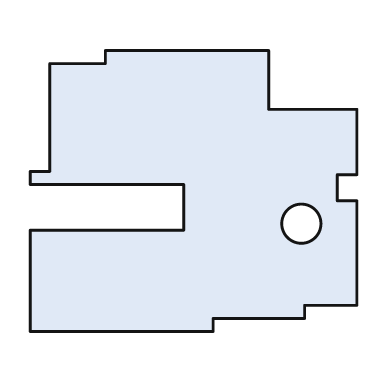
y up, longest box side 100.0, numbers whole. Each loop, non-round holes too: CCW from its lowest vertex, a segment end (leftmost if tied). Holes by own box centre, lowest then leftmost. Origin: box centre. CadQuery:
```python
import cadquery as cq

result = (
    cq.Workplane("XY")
    .moveTo(-50.0, -43.0)
    .lineTo(6.0, -43.0)
    .lineTo(6.0, -39.0)
    .lineTo(34.0, -39.0)
    .lineTo(34.0, -35.0)
    .lineTo(50.0, -35.0)
    .lineTo(50.0, -3.0)
    .lineTo(44.0, -3.0)
    .lineTo(44.0, 5.0)
    .lineTo(50.0, 5.0)
    .lineTo(50.0, 25.0)
    .lineTo(23.0, 25.0)
    .lineTo(23.0, 43.0)
    .lineTo(-27.0, 43.0)
    .lineTo(-27.0, 39.0)
    .lineTo(-44.0, 39.0)
    .lineTo(-44.0, 6.0)
    .lineTo(-50.0, 6.0)
    .lineTo(-50.0, 2.0)
    .lineTo(-3.0, 2.0)
    .lineTo(-3.0, -12.0)
    .lineTo(-50.0, -12.0)
    .close()
    .moveTo(33.0, -10.0)
    .circle(6.0)
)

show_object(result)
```